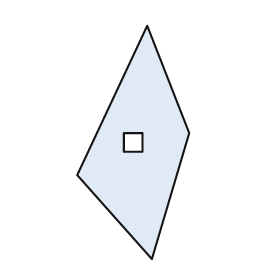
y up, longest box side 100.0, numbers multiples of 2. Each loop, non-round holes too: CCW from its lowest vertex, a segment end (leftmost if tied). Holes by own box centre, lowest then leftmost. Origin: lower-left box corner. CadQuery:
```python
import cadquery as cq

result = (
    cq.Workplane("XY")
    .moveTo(32.0, 0.0)
    .lineTo(48.0, 54.0)
    .lineTo(30.0, 100.0)
    .lineTo(0.0, 36.0)
    .close()
    .moveTo(20.0, 46.0)
    .lineTo(28.0, 46.0)
    .lineTo(28.0, 54.0)
    .lineTo(20.0, 54.0)
    .close()
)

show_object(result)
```